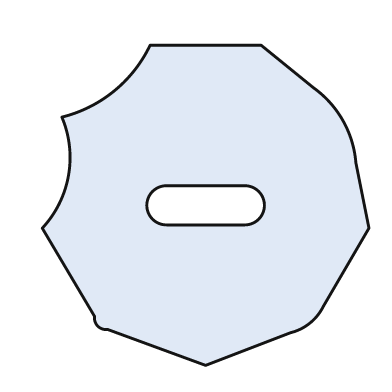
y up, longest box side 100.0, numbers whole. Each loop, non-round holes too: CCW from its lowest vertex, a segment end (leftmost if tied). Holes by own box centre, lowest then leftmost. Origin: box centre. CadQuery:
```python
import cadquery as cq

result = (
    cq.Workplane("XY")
    .moveTo(0.0, -49.0)
    .lineTo(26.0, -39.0)
    .threePointArc((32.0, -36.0), (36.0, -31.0))
    .lineTo(50.0, -7.0)
    .lineTo(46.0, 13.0)
    .threePointArc((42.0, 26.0), (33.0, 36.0))
    .lineTo(17.0, 49.0)
    .lineTo(-17.0, 49.0)
    .threePointArc((-28.0, 35.0), (-44.0, 27.0))
    .threePointArc((-42.0, 9.0), (-50.0, -7.0))
    .lineTo(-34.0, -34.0)
    .threePointArc((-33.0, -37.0), (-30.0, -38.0))
    .close()
    .moveTo(-12.0, -6.0)
    .lineTo(12.0, -6.0)
    .threePointArc((18.0, 0.0), (12.0, 6.0))
    .lineTo(-12.0, 6.0)
    .threePointArc((-18.0, 0.0), (-12.0, -6.0))
    .close()
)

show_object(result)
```